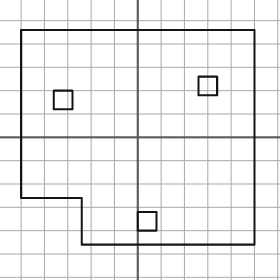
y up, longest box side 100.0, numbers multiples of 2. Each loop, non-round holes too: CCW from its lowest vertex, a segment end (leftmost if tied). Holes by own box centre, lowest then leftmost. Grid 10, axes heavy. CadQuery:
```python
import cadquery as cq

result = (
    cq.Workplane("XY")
    .moveTo(-24.0, -46.0)
    .lineTo(50.0, -46.0)
    .lineTo(50.0, 46.0)
    .lineTo(-50.0, 46.0)
    .lineTo(-50.0, -26.0)
    .lineTo(-24.0, -26.0)
    .close()
    .moveTo(0.0, -40.0)
    .lineTo(8.0, -40.0)
    .lineTo(8.0, -32.0)
    .lineTo(0.0, -32.0)
    .close()
    .moveTo(-36.0, 12.0)
    .lineTo(-28.0, 12.0)
    .lineTo(-28.0, 20.0)
    .lineTo(-36.0, 20.0)
    .close()
    .moveTo(26.0, 18.0)
    .lineTo(34.0, 18.0)
    .lineTo(34.0, 26.0)
    .lineTo(26.0, 26.0)
    .close()
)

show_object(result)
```